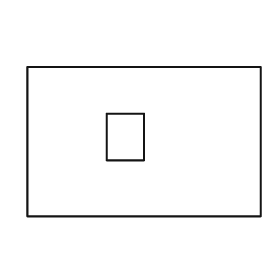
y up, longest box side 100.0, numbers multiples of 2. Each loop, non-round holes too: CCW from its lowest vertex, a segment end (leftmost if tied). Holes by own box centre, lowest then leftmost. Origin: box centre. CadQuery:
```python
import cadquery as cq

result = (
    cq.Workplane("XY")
    .moveTo(-50.0, -32.0)
    .lineTo(50.0, -32.0)
    .lineTo(50.0, 32.0)
    .lineTo(-50.0, 32.0)
    .close()
    .moveTo(-16.0, -8.0)
    .lineTo(0.0, -8.0)
    .lineTo(0.0, 12.0)
    .lineTo(-16.0, 12.0)
    .close()
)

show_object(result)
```